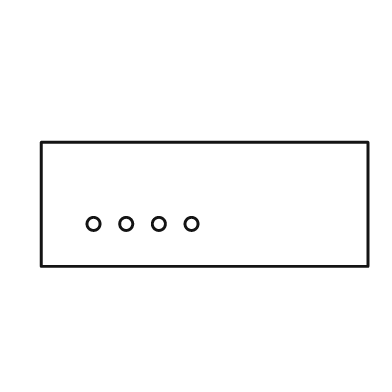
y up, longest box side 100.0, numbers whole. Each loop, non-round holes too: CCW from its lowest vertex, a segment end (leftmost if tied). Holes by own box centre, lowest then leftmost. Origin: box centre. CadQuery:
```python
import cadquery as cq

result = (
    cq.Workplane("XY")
    .moveTo(-50.0, -19.0)
    .lineTo(50.0, -19.0)
    .lineTo(50.0, 19.0)
    .lineTo(-50.0, 19.0)
    .close()
    .moveTo(-34.0, -6.0)
    .circle(2.0)
    .moveTo(-24.0, -6.0)
    .circle(2.0)
    .moveTo(-14.0, -6.0)
    .circle(2.0)
    .moveTo(-4.0, -6.0)
    .circle(2.0)
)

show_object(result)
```